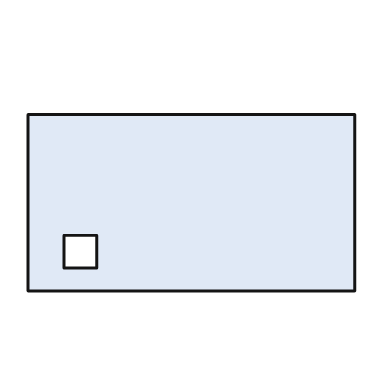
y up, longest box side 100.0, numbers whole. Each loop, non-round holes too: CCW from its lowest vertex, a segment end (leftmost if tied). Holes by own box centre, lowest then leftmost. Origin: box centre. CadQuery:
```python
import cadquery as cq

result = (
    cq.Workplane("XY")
    .moveTo(-50.0, -27.0)
    .lineTo(50.0, -27.0)
    .lineTo(50.0, 27.0)
    .lineTo(-50.0, 27.0)
    .close()
    .moveTo(-39.0, -20.0)
    .lineTo(-29.0, -20.0)
    .lineTo(-29.0, -10.0)
    .lineTo(-39.0, -10.0)
    .close()
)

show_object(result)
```